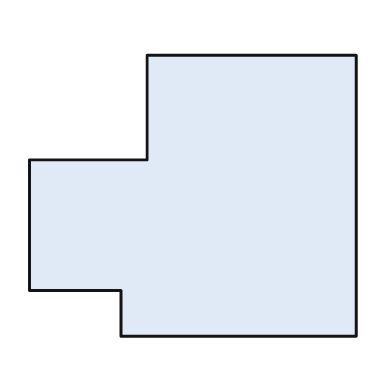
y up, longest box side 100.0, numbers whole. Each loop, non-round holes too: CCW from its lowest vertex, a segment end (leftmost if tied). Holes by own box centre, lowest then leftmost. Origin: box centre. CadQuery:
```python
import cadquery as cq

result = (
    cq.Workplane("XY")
    .moveTo(-22.0, -43.0)
    .lineTo(50.0, -43.0)
    .lineTo(50.0, 43.0)
    .lineTo(-14.0, 43.0)
    .lineTo(-14.0, 11.0)
    .lineTo(-50.0, 11.0)
    .lineTo(-50.0, -29.0)
    .lineTo(-22.0, -29.0)
    .close()
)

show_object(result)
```